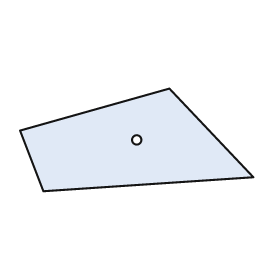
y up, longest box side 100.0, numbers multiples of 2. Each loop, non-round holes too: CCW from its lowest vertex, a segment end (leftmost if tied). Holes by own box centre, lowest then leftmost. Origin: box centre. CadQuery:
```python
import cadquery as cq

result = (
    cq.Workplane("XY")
    .moveTo(-40.0, -22.0)
    .lineTo(50.0, -16.0)
    .lineTo(14.0, 22.0)
    .lineTo(-50.0, 4.0)
    .close()
    .moveTo(0.0, 0.0)
    .circle(2.0)
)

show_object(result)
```